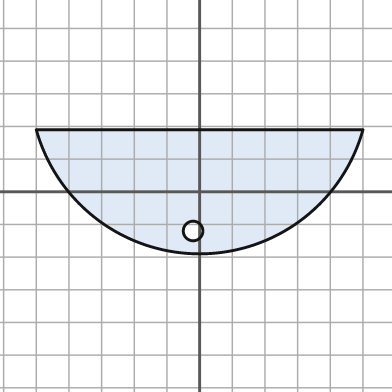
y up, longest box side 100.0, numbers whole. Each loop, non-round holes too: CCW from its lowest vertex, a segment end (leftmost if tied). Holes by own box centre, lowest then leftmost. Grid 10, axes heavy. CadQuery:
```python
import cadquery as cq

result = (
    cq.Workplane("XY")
    .moveTo(-50.0, 19.0)
    .threePointArc((0.0, -19.0), (50.0, 19.0))
    .close()
    .moveTo(-2.0, -12.0)
    .circle(3.0)
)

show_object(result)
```